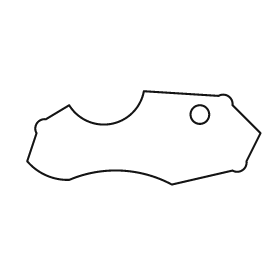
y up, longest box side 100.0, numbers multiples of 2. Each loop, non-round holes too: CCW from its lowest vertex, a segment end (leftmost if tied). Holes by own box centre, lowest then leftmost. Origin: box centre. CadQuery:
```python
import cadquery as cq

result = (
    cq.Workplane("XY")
    .moveTo(12.0, -20.0)
    .lineTo(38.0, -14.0)
    .threePointArc((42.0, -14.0), (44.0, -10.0))
    .lineTo(50.0, 2.0)
    .lineTo(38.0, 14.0)
    .threePointArc((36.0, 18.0), (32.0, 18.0))
    .lineTo(0.0, 20.0)
    .threePointArc((-14.0, 6.0), (-32.0, 14.0))
    .lineTo(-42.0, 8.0)
    .threePointArc((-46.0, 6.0), (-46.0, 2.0))
    .lineTo(-50.0, -10.0)
    .threePointArc((-42.0, -16.0), (-32.0, -18.0))
    .threePointArc((-10.0, -14.0), (12.0, -20.0))
    .close()
    .moveTo(24.0, 10.0)
    .circle(4.0)
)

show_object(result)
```